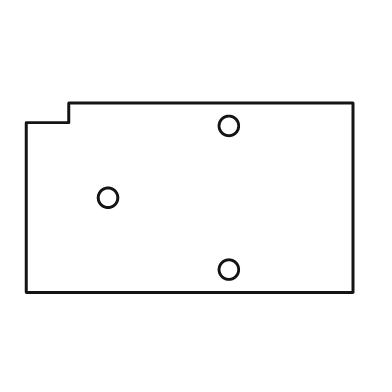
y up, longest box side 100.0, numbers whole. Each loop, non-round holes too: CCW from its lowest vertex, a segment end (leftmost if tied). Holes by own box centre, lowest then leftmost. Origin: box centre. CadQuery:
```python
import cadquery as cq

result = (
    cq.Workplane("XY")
    .moveTo(-50.0, -29.0)
    .lineTo(50.0, -29.0)
    .lineTo(50.0, 29.0)
    .lineTo(-37.0, 29.0)
    .lineTo(-37.0, 23.0)
    .lineTo(-50.0, 23.0)
    .close()
    .moveTo(12.0, -22.0)
    .circle(3.0)
    .moveTo(-25.0, 0.0)
    .circle(3.0)
    .moveTo(12.0, 22.0)
    .circle(3.0)
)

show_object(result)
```